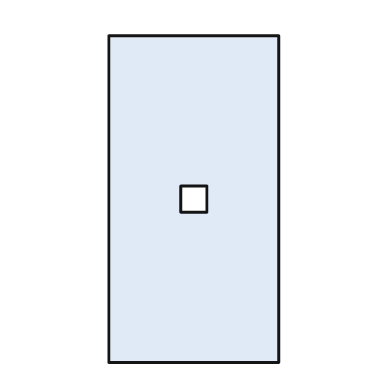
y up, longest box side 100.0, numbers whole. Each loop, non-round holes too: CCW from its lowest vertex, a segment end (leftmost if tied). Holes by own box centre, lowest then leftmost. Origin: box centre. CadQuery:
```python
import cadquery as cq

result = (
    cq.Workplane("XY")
    .moveTo(-26.0, -50.0)
    .lineTo(26.0, -50.0)
    .lineTo(26.0, 50.0)
    .lineTo(-26.0, 50.0)
    .close()
    .moveTo(-4.0, -4.0)
    .lineTo(4.0, -4.0)
    .lineTo(4.0, 4.0)
    .lineTo(-4.0, 4.0)
    .close()
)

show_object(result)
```